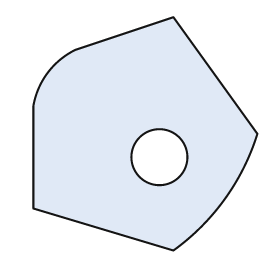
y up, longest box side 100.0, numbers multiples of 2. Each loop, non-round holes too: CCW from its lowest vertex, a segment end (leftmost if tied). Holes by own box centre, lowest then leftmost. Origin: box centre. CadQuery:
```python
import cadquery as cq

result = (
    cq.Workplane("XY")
    .moveTo(12.0, -50.0)
    .threePointArc((34.0, -28.0), (48.0, 0.0))
    .lineTo(12.0, 50.0)
    .lineTo(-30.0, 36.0)
    .threePointArc((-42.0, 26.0), (-48.0, 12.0))
    .lineTo(-48.0, -32.0)
    .close()
    .moveTo(6.0, -10.0)
    .circle(12.0)
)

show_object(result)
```